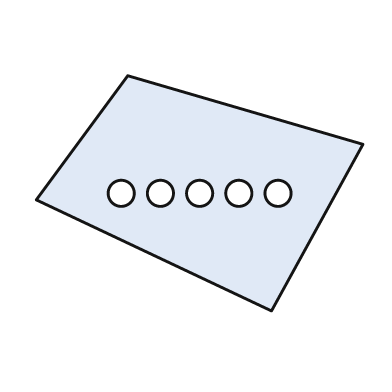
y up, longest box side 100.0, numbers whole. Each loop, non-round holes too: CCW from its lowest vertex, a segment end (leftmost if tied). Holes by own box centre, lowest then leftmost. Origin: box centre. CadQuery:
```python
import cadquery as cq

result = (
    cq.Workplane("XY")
    .moveTo(22.0, -36.0)
    .lineTo(50.0, 15.0)
    .lineTo(-22.0, 36.0)
    .lineTo(-50.0, -2.0)
    .close()
    .moveTo(-24.0, 0.0)
    .circle(4.0)
    .moveTo(-12.0, 0.0)
    .circle(4.0)
    .moveTo(0.0, 0.0)
    .circle(4.0)
    .moveTo(12.0, 0.0)
    .circle(4.0)
    .moveTo(24.0, 0.0)
    .circle(4.0)
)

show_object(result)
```